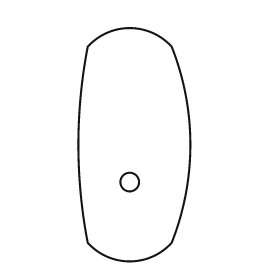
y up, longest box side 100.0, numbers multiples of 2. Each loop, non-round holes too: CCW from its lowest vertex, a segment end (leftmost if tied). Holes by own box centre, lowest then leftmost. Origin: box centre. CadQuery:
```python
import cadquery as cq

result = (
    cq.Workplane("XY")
    .moveTo(-20.0, -42.0)
    .threePointArc((-2.0, -50.0), (16.0, -42.0))
    .threePointArc((24.0, 0.0), (16.0, 42.0))
    .threePointArc((-2.0, 50.0), (-20.0, 42.0))
    .threePointArc((-24.0, 0.0), (-20.0, -42.0))
    .close()
    .moveTo(-2.0, -16.0)
    .circle(4.0)
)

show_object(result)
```